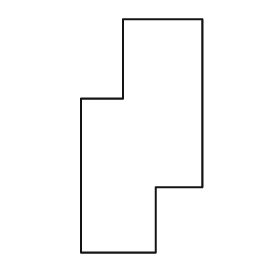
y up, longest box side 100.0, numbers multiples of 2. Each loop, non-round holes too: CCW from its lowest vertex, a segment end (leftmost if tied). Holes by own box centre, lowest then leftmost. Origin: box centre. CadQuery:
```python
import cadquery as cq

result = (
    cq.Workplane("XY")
    .moveTo(-26.0, -50.0)
    .lineTo(6.0, -50.0)
    .lineTo(6.0, -22.0)
    .lineTo(26.0, -22.0)
    .lineTo(26.0, 50.0)
    .lineTo(-8.0, 50.0)
    .lineTo(-8.0, 16.0)
    .lineTo(-26.0, 16.0)
    .close()
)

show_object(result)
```